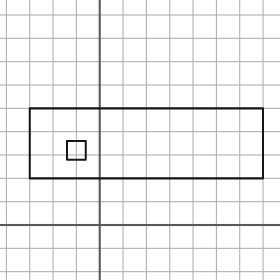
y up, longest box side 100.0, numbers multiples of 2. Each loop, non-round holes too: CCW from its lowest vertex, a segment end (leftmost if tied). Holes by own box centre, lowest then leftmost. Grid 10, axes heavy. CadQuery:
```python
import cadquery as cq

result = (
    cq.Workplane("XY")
    .moveTo(-30.0, 20.0)
    .lineTo(70.0, 20.0)
    .lineTo(70.0, 50.0)
    .lineTo(-30.0, 50.0)
    .close()
    .moveTo(-14.0, 28.0)
    .lineTo(-6.0, 28.0)
    .lineTo(-6.0, 36.0)
    .lineTo(-14.0, 36.0)
    .close()
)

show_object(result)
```